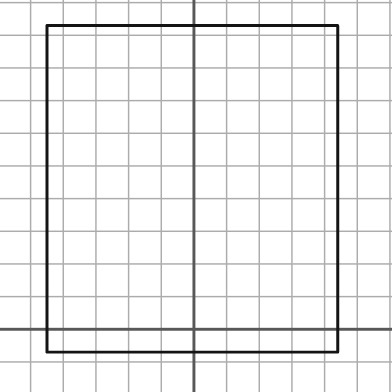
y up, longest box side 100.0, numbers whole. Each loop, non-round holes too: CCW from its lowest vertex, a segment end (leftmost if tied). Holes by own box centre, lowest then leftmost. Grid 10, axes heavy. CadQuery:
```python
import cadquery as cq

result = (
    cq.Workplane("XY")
    .moveTo(-45.0, -7.0)
    .lineTo(44.0, -7.0)
    .lineTo(44.0, 93.0)
    .lineTo(-45.0, 93.0)
    .close()
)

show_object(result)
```